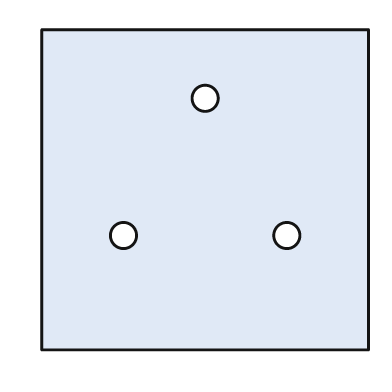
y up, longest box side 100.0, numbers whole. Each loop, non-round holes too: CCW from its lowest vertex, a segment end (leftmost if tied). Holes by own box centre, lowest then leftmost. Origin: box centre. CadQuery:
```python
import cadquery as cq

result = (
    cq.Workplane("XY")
    .moveTo(-50.0, -49.0)
    .lineTo(50.0, -49.0)
    .lineTo(50.0, 49.0)
    .lineTo(-50.0, 49.0)
    .close()
    .moveTo(-25.0, -14.0)
    .circle(4.0)
    .moveTo(25.0, -14.0)
    .circle(4.0)
    .moveTo(0.0, 28.0)
    .circle(4.0)
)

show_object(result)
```